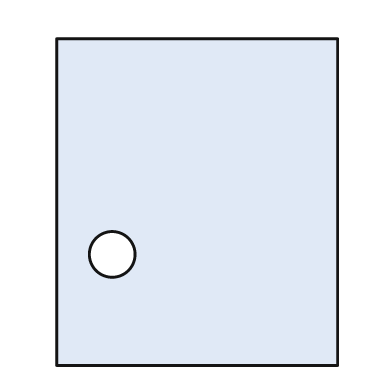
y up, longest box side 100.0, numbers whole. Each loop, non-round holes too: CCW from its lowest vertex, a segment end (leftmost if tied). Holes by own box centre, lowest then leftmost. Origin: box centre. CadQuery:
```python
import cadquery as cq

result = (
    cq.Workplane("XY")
    .moveTo(-43.0, -50.0)
    .lineTo(43.0, -50.0)
    .lineTo(43.0, 50.0)
    .lineTo(-43.0, 50.0)
    .close()
    .moveTo(-26.0, -16.0)
    .circle(7.0)
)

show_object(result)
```